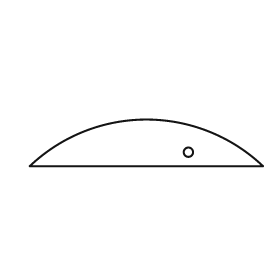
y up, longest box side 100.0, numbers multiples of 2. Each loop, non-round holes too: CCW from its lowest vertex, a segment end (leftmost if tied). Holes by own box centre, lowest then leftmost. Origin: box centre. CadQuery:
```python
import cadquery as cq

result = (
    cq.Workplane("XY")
    .moveTo(-50.0, -10.0)
    .lineTo(50.0, -10.0)
    .threePointArc((0.0, 10.0), (-50.0, -10.0))
    .close()
    .moveTo(18.0, -4.0)
    .circle(2.0)
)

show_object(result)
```